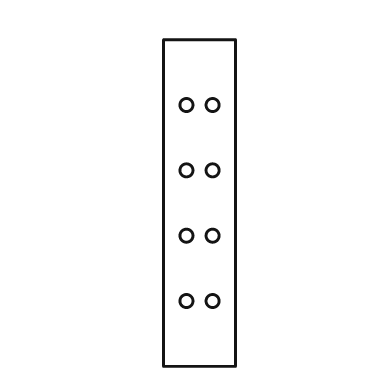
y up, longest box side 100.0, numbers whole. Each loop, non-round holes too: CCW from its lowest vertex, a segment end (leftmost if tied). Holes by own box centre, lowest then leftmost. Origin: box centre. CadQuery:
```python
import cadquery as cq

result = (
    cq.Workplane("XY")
    .moveTo(-11.0, -50.0)
    .lineTo(11.0, -50.0)
    .lineTo(11.0, 50.0)
    .lineTo(-11.0, 50.0)
    .close()
    .moveTo(-4.0, -30.0)
    .circle(2.0)
    .moveTo(4.0, -30.0)
    .circle(2.0)
    .moveTo(-4.0, -10.0)
    .circle(2.0)
    .moveTo(4.0, -10.0)
    .circle(2.0)
    .moveTo(-4.0, 10.0)
    .circle(2.0)
    .moveTo(4.0, 10.0)
    .circle(2.0)
    .moveTo(-4.0, 30.0)
    .circle(2.0)
    .moveTo(4.0, 30.0)
    .circle(2.0)
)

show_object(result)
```